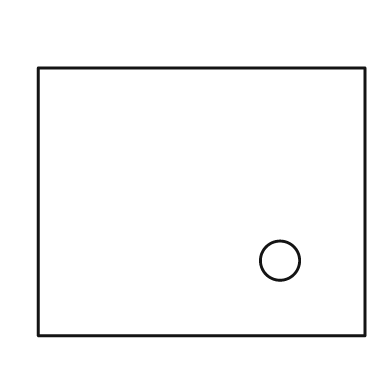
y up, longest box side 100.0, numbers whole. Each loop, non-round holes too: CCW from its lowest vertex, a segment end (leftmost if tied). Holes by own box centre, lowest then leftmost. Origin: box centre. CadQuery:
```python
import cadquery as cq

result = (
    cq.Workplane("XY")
    .moveTo(-50.0, -41.0)
    .lineTo(50.0, -41.0)
    .lineTo(50.0, 41.0)
    .lineTo(-50.0, 41.0)
    .close()
    .moveTo(24.0, -18.0)
    .circle(6.0)
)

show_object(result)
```